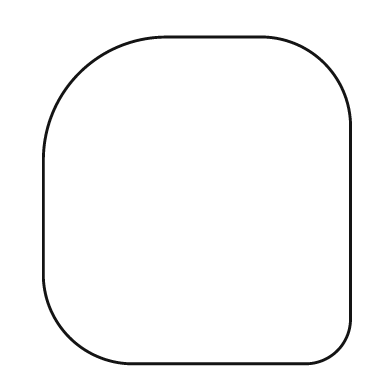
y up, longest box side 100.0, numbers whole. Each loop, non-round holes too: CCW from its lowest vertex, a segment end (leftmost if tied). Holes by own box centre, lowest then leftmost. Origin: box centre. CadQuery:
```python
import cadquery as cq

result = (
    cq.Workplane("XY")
    .moveTo(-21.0, -50.0)
    .lineTo(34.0, -50.0)
    .threePointArc((43.0, -46.0), (47.0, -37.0))
    .lineTo(47.0, 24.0)
    .threePointArc((39.0, 42.0), (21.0, 50.0))
    .lineTo(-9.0, 50.0)
    .threePointArc((-36.0, 39.0), (-47.0, 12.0))
    .lineTo(-47.0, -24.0)
    .threePointArc((-39.0, -42.0), (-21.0, -50.0))
    .close()
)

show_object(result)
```